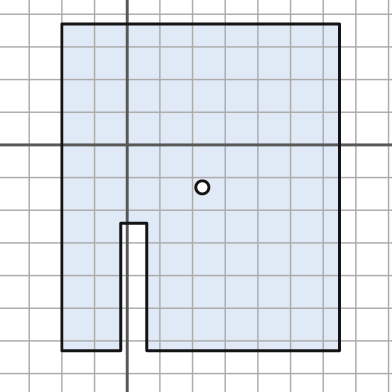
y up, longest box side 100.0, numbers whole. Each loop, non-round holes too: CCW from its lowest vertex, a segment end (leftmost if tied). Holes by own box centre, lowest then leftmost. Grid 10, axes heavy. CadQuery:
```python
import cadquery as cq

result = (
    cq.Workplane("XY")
    .moveTo(-20.0, -63.0)
    .lineTo(-2.0, -63.0)
    .lineTo(-2.0, -24.0)
    .lineTo(6.0, -24.0)
    .lineTo(6.0, -63.0)
    .lineTo(65.0, -63.0)
    .lineTo(65.0, 37.0)
    .lineTo(-20.0, 37.0)
    .close()
    .moveTo(23.0, -13.0)
    .circle(2.0)
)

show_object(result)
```